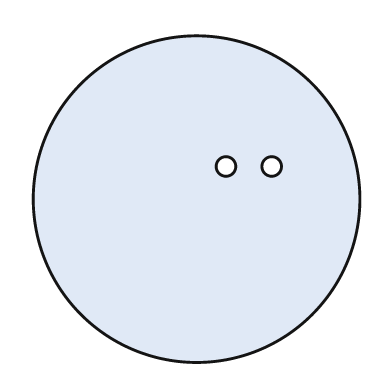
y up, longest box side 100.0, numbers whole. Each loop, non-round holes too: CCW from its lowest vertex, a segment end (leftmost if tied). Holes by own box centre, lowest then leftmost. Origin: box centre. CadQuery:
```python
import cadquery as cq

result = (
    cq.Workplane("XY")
    .moveTo(0.0, 0.0)
    .circle(50.0)
    .moveTo(9.0, 10.0)
    .circle(3.0)
    .moveTo(23.0, 10.0)
    .circle(3.0)
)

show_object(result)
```